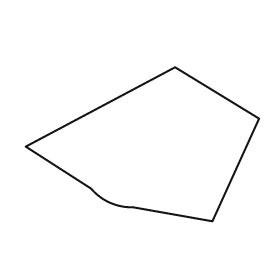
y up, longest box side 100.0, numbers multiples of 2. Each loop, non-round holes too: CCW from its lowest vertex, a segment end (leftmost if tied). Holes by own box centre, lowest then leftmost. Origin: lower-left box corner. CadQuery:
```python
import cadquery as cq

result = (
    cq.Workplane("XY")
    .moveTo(80.0, 0.0)
    .lineTo(100.0, 44.0)
    .lineTo(64.0, 66.0)
    .lineTo(0.0, 32.0)
    .lineTo(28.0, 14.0)
    .threePointArc((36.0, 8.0), (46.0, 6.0))
    .close()
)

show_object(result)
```